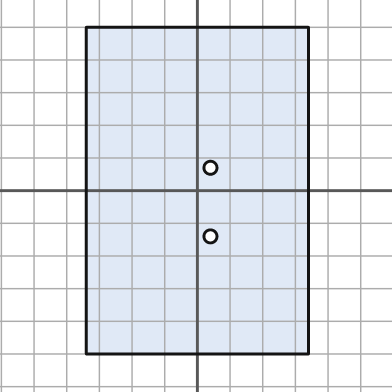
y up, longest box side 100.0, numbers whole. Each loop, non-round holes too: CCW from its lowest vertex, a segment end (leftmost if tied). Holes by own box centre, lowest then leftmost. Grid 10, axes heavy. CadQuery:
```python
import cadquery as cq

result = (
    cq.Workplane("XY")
    .moveTo(-34.0, -50.0)
    .lineTo(34.0, -50.0)
    .lineTo(34.0, 50.0)
    .lineTo(-34.0, 50.0)
    .close()
    .moveTo(4.0, -14.0)
    .circle(2.0)
    .moveTo(4.0, 7.0)
    .circle(2.0)
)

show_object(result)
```